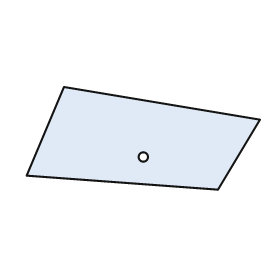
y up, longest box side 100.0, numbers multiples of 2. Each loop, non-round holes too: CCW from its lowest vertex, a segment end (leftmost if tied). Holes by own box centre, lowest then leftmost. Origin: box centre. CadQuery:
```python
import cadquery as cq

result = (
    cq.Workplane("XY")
    .moveTo(32.0, -22.0)
    .lineTo(50.0, 8.0)
    .lineTo(-34.0, 22.0)
    .lineTo(-50.0, -16.0)
    .close()
    .moveTo(0.0, -8.0)
    .circle(2.0)
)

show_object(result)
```